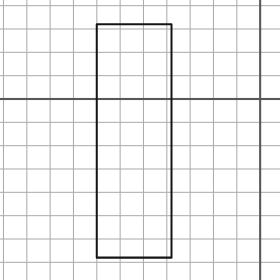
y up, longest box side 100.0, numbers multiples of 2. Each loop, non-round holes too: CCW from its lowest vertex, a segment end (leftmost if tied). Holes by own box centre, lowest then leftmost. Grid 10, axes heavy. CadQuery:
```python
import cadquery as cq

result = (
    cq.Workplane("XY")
    .moveTo(-70.0, -68.0)
    .lineTo(-38.0, -68.0)
    .lineTo(-38.0, 32.0)
    .lineTo(-70.0, 32.0)
    .close()
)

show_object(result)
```